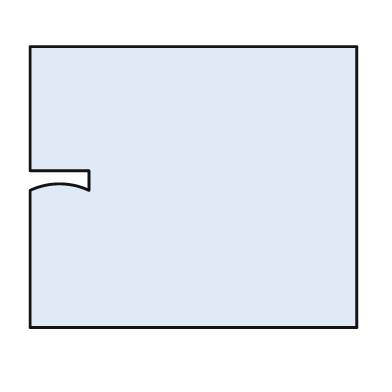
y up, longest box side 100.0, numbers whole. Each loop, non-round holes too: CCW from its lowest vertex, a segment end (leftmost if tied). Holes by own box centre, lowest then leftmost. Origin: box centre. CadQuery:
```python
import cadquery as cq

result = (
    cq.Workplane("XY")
    .moveTo(-50.0, -43.0)
    .lineTo(50.0, -43.0)
    .lineTo(50.0, 43.0)
    .lineTo(-50.0, 43.0)
    .lineTo(-50.0, 5.0)
    .lineTo(-32.0, 5.0)
    .lineTo(-32.0, -1.0)
    .threePointArc((-41.0, 1.0), (-50.0, -1.0))
    .close()
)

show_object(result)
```